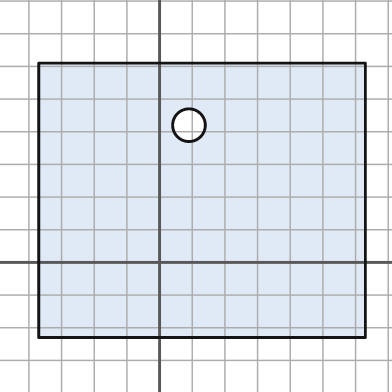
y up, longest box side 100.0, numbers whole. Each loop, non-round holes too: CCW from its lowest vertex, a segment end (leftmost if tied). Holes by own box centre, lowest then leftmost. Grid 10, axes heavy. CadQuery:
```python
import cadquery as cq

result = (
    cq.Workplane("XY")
    .moveTo(-37.0, -23.0)
    .lineTo(63.0, -23.0)
    .lineTo(63.0, 61.0)
    .lineTo(-37.0, 61.0)
    .close()
    .moveTo(9.0, 42.0)
    .circle(5.0)
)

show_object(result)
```